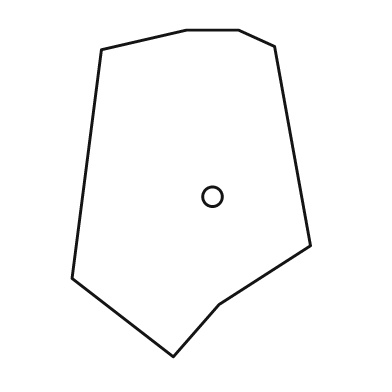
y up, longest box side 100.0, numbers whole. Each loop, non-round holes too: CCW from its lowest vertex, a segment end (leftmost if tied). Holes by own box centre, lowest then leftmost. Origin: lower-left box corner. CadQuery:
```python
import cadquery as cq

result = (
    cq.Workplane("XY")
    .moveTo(31.0, 0.0)
    .lineTo(45.0, 16.0)
    .lineTo(73.0, 34.0)
    .lineTo(62.0, 95.0)
    .lineTo(51.0, 100.0)
    .lineTo(35.0, 100.0)
    .lineTo(9.0, 94.0)
    .lineTo(0.0, 24.0)
    .close()
    .moveTo(43.0, 49.0)
    .circle(3.0)
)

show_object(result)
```